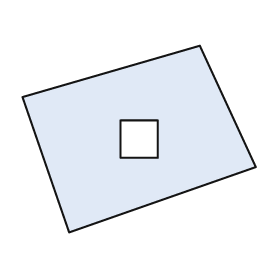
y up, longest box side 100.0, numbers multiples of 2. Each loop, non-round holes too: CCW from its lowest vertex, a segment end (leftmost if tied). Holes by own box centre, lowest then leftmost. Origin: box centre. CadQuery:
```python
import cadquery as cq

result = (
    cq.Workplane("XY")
    .moveTo(-30.0, -40.0)
    .lineTo(50.0, -12.0)
    .lineTo(26.0, 40.0)
    .lineTo(-50.0, 18.0)
    .close()
    .moveTo(-8.0, -8.0)
    .lineTo(8.0, -8.0)
    .lineTo(8.0, 8.0)
    .lineTo(-8.0, 8.0)
    .close()
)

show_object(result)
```